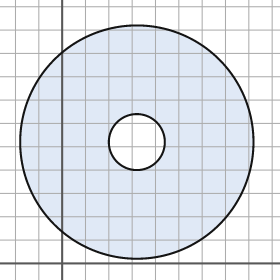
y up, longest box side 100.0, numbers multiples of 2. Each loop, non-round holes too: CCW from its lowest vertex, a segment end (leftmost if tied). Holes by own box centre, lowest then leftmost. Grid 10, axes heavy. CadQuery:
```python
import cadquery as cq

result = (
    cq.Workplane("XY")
    .moveTo(32.0, 52.0)
    .circle(50.0)
    .moveTo(32.0, 52.0)
    .circle(12.0)
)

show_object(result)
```